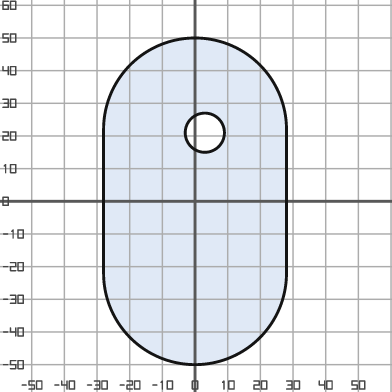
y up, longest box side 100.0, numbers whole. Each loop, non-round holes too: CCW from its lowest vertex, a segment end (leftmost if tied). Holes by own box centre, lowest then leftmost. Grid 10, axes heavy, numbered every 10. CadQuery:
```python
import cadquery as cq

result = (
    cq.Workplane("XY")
    .moveTo(-28.0, -22.0)
    .threePointArc((0.0, -50.0), (28.0, -22.0))
    .lineTo(28.0, 22.0)
    .threePointArc((0.0, 50.0), (-28.0, 22.0))
    .close()
    .moveTo(3.0, 21.0)
    .circle(6.0)
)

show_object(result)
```